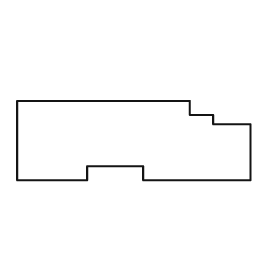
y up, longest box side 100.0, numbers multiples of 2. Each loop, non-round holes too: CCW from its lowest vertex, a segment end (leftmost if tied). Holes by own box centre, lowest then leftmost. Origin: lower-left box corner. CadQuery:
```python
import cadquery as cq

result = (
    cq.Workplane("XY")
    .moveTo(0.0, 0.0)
    .lineTo(30.0, 0.0)
    .lineTo(30.0, 6.0)
    .lineTo(54.0, 6.0)
    .lineTo(54.0, 0.0)
    .lineTo(100.0, 0.0)
    .lineTo(100.0, 24.0)
    .lineTo(84.0, 24.0)
    .lineTo(84.0, 28.0)
    .lineTo(74.0, 28.0)
    .lineTo(74.0, 34.0)
    .lineTo(0.0, 34.0)
    .close()
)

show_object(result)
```